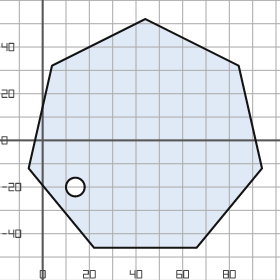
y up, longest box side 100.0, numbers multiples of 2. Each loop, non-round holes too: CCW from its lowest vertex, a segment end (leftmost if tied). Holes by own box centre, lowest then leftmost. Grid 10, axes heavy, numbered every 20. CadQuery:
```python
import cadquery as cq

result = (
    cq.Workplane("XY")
    .moveTo(22.0, -46.0)
    .lineTo(66.0, -46.0)
    .lineTo(94.0, -12.0)
    .lineTo(84.0, 32.0)
    .lineTo(44.0, 52.0)
    .lineTo(4.0, 32.0)
    .lineTo(-6.0, -12.0)
    .close()
    .moveTo(14.0, -20.0)
    .circle(4.0)
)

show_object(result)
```